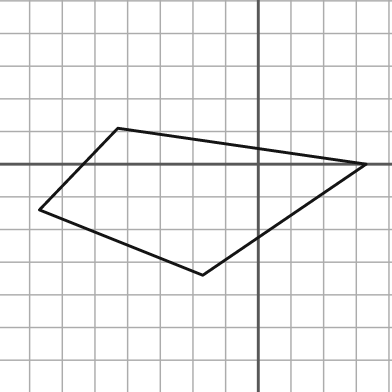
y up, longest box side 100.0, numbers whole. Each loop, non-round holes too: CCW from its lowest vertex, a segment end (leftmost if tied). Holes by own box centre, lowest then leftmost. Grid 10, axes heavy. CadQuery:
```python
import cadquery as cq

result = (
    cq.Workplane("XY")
    .moveTo(-17.0, -34.0)
    .lineTo(33.0, 0.0)
    .lineTo(-43.0, 11.0)
    .lineTo(-67.0, -14.0)
    .close()
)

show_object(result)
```